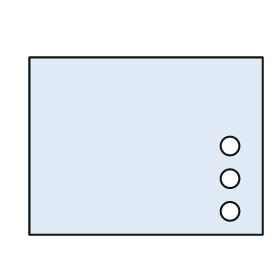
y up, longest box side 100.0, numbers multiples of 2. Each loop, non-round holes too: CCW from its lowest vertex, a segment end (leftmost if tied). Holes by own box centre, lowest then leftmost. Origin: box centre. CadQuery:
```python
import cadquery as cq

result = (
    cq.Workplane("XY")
    .moveTo(-50.0, -38.0)
    .lineTo(50.0, -38.0)
    .lineTo(50.0, 38.0)
    .lineTo(-50.0, 38.0)
    .close()
    .moveTo(36.0, -28.0)
    .circle(4.0)
    .moveTo(36.0, -14.0)
    .circle(4.0)
    .moveTo(36.0, 0.0)
    .circle(4.0)
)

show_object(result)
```